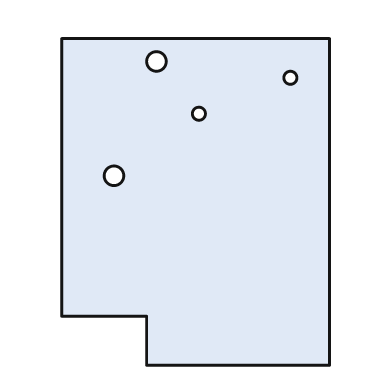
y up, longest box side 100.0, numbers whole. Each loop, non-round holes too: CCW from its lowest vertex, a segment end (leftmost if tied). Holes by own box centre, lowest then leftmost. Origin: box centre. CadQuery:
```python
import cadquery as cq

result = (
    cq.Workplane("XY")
    .moveTo(-15.0, -50.0)
    .lineTo(41.0, -50.0)
    .lineTo(41.0, 50.0)
    .lineTo(-41.0, 50.0)
    .lineTo(-41.0, -35.0)
    .lineTo(-15.0, -35.0)
    .close()
    .moveTo(-25.0, 8.0)
    .circle(3.0)
    .moveTo(1.0, 27.0)
    .circle(2.0)
    .moveTo(29.0, 38.0)
    .circle(2.0)
    .moveTo(-12.0, 43.0)
    .circle(3.0)
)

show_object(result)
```